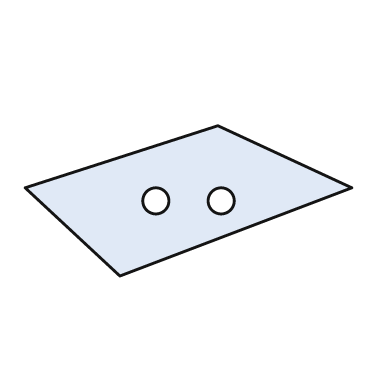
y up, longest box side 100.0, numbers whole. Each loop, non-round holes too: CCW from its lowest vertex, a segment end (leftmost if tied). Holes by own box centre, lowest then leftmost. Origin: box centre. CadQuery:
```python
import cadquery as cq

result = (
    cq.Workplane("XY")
    .moveTo(-21.0, -23.0)
    .lineTo(50.0, 4.0)
    .lineTo(9.0, 23.0)
    .lineTo(-50.0, 4.0)
    .close()
    .moveTo(-10.0, 0.0)
    .circle(4.0)
    .moveTo(10.0, 0.0)
    .circle(4.0)
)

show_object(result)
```